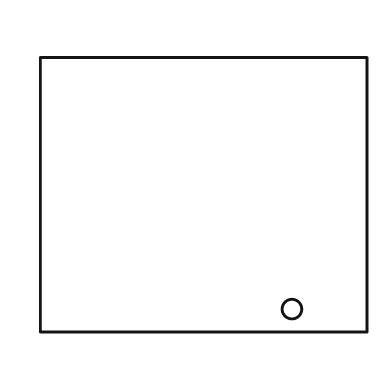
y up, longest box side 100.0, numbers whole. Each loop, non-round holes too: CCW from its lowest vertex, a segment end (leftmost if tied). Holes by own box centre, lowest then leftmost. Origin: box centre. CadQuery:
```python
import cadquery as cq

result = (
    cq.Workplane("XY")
    .moveTo(-50.0, -42.0)
    .lineTo(50.0, -42.0)
    .lineTo(50.0, 42.0)
    .lineTo(-50.0, 42.0)
    .close()
    .moveTo(27.0, -35.0)
    .circle(3.0)
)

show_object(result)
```